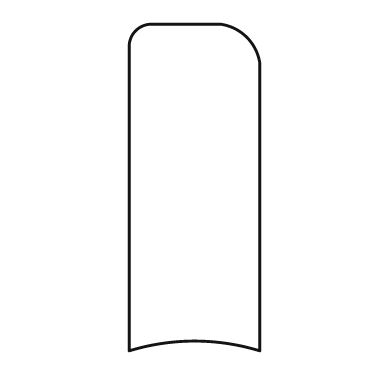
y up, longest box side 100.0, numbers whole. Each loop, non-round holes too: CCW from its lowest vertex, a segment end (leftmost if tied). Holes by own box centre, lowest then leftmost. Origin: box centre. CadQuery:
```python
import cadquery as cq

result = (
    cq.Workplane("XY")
    .moveTo(-20.0, -50.0)
    .threePointArc((0.0, -47.0), (20.0, -50.0))
    .lineTo(20.0, 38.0)
    .threePointArc((16.0, 46.0), (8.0, 50.0))
    .lineTo(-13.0, 50.0)
    .threePointArc((-18.0, 48.0), (-20.0, 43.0))
    .close()
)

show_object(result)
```